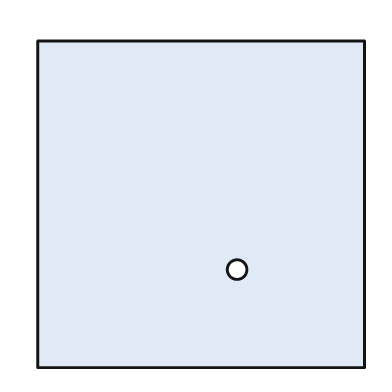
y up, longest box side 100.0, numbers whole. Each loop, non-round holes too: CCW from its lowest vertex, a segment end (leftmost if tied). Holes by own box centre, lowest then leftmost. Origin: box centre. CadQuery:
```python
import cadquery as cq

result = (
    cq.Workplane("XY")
    .moveTo(-50.0, -50.0)
    .lineTo(50.0, -50.0)
    .lineTo(50.0, 50.0)
    .lineTo(-50.0, 50.0)
    .close()
    .moveTo(11.0, -20.0)
    .circle(3.0)
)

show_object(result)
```